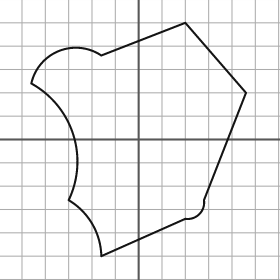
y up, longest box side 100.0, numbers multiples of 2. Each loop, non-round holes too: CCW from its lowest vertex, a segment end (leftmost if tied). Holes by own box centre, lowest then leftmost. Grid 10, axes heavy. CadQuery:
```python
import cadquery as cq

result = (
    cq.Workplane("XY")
    .moveTo(-16.0, -50.0)
    .lineTo(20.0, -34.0)
    .threePointArc((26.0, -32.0), (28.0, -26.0))
    .lineTo(46.0, 20.0)
    .lineTo(20.0, 50.0)
    .lineTo(-16.0, 36.0)
    .threePointArc((-34.0, 38.0), (-46.0, 24.0))
    .threePointArc((-28.0, 2.0), (-30.0, -26.0))
    .threePointArc((-20.0, -36.0), (-16.0, -50.0))
    .close()
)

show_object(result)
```